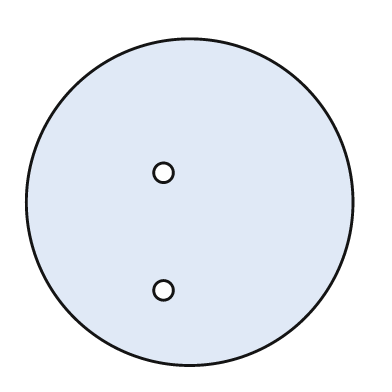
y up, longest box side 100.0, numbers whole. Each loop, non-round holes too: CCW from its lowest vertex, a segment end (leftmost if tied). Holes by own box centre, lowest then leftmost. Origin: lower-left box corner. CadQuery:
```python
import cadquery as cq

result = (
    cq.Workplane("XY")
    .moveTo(50.0, 50.0)
    .circle(50.0)
    .moveTo(42.0, 23.0)
    .circle(3.0)
    .moveTo(42.0, 59.0)
    .circle(3.0)
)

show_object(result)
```